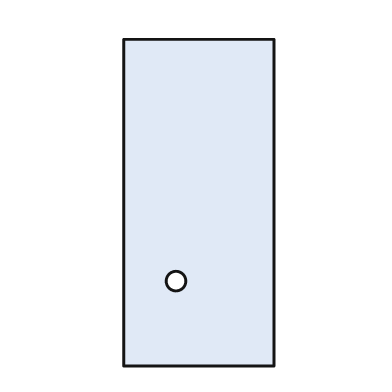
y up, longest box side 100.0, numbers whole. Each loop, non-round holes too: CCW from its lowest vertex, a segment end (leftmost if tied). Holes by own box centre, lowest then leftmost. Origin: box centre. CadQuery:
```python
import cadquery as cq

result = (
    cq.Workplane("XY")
    .moveTo(-23.0, -50.0)
    .lineTo(23.0, -50.0)
    .lineTo(23.0, 50.0)
    .lineTo(-23.0, 50.0)
    .close()
    .moveTo(-7.0, -24.0)
    .circle(3.0)
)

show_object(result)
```